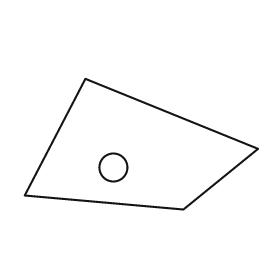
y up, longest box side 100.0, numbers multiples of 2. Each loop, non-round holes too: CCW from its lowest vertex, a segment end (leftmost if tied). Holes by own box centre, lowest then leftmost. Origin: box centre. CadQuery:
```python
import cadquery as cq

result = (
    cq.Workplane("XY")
    .moveTo(18.0, -28.0)
    .lineTo(50.0, -2.0)
    .lineTo(-24.0, 28.0)
    .lineTo(-50.0, -22.0)
    .close()
    .moveTo(-12.0, -10.0)
    .circle(6.0)
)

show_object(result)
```